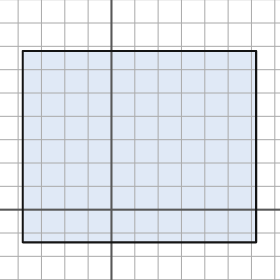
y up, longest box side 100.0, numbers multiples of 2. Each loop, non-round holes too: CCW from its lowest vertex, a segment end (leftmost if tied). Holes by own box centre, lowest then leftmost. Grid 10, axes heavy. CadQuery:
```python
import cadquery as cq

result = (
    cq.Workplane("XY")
    .moveTo(-38.0, -14.0)
    .lineTo(62.0, -14.0)
    .lineTo(62.0, 68.0)
    .lineTo(-38.0, 68.0)
    .close()
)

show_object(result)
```